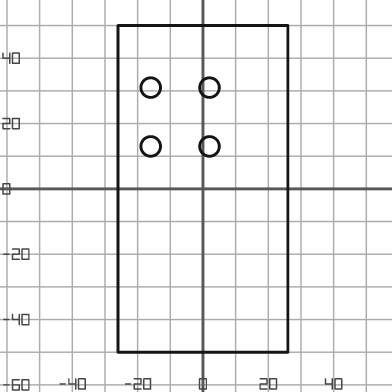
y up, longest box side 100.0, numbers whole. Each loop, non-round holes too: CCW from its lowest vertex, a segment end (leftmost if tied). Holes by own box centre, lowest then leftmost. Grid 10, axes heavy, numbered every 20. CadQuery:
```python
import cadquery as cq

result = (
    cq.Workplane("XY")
    .moveTo(-26.0, -50.0)
    .lineTo(26.0, -50.0)
    .lineTo(26.0, 50.0)
    .lineTo(-26.0, 50.0)
    .close()
    .moveTo(-16.0, 13.0)
    .circle(3.0)
    .moveTo(2.0, 13.0)
    .circle(3.0)
    .moveTo(-16.0, 31.0)
    .circle(3.0)
    .moveTo(2.0, 31.0)
    .circle(3.0)
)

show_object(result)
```